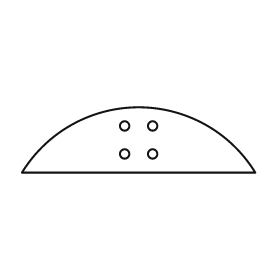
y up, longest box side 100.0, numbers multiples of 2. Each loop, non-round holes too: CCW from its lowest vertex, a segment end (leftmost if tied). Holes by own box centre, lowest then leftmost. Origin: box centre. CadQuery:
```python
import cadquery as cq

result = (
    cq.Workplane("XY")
    .moveTo(-50.0, -14.0)
    .lineTo(50.0, -14.0)
    .threePointArc((0.0, 14.0), (-50.0, -14.0))
    .close()
    .moveTo(-6.0, -6.0)
    .circle(2.0)
    .moveTo(6.0, -6.0)
    .circle(2.0)
    .moveTo(-6.0, 6.0)
    .circle(2.0)
    .moveTo(6.0, 6.0)
    .circle(2.0)
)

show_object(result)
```